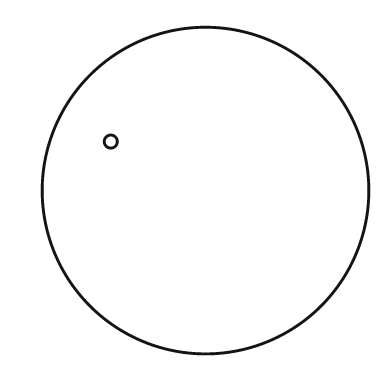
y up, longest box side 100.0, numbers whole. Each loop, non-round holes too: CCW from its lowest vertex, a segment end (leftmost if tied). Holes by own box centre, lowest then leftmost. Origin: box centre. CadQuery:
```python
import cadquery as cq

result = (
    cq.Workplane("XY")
    .moveTo(0.0, 0.0)
    .circle(50.0)
    .moveTo(-29.0, 15.0)
    .circle(2.0)
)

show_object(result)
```